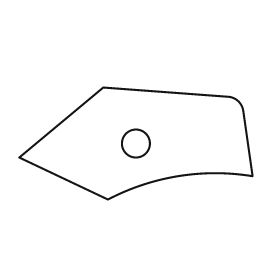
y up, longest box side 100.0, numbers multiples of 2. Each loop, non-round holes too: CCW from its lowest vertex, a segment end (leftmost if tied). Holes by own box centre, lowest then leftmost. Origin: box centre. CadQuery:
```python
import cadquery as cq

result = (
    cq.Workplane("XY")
    .moveTo(-12.0, -24.0)
    .threePointArc((18.0, -14.0), (50.0, -14.0))
    .lineTo(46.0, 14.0)
    .threePointArc((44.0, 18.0), (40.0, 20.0))
    .lineTo(-14.0, 24.0)
    .lineTo(-50.0, -6.0)
    .close()
    .moveTo(0.0, 0.0)
    .circle(6.0)
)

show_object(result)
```